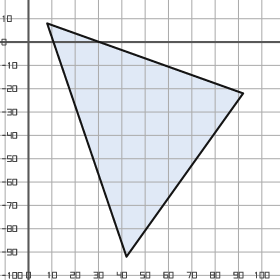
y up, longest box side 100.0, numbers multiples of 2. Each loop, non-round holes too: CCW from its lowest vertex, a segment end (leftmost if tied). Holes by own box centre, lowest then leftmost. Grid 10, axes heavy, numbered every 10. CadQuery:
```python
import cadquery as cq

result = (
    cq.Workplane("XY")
    .moveTo(42.0, -92.0)
    .lineTo(92.0, -22.0)
    .lineTo(8.0, 8.0)
    .close()
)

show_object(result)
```